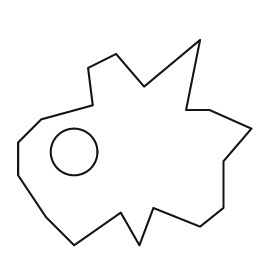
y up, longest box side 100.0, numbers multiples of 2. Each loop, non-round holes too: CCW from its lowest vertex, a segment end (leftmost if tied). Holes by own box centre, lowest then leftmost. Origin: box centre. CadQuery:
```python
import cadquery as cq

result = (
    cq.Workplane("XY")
    .moveTo(-26.0, -44.0)
    .lineTo(-6.0, -30.0)
    .lineTo(2.0, -44.0)
    .lineTo(8.0, -28.0)
    .lineTo(28.0, -36.0)
    .lineTo(38.0, -28.0)
    .lineTo(38.0, -8.0)
    .lineTo(50.0, 6.0)
    .lineTo(32.0, 14.0)
    .lineTo(22.0, 14.0)
    .lineTo(28.0, 44.0)
    .lineTo(4.0, 24.0)
    .lineTo(-8.0, 38.0)
    .lineTo(-20.0, 32.0)
    .lineTo(-18.0, 16.0)
    .lineTo(-40.0, 10.0)
    .lineTo(-50.0, 0.0)
    .lineTo(-50.0, -14.0)
    .lineTo(-38.0, -32.0)
    .close()
    .moveTo(-26.0, -4.0)
    .circle(10.0)
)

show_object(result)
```